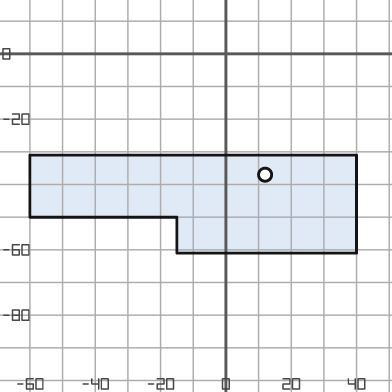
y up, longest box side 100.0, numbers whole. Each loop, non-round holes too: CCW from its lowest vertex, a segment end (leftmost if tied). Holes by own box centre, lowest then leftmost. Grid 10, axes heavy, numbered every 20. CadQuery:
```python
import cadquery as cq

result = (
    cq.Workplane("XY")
    .moveTo(-15.0, -61.0)
    .lineTo(40.0, -61.0)
    .lineTo(40.0, -31.0)
    .lineTo(-60.0, -31.0)
    .lineTo(-60.0, -50.0)
    .lineTo(-15.0, -50.0)
    .close()
    .moveTo(12.0, -37.0)
    .circle(2.0)
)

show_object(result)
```